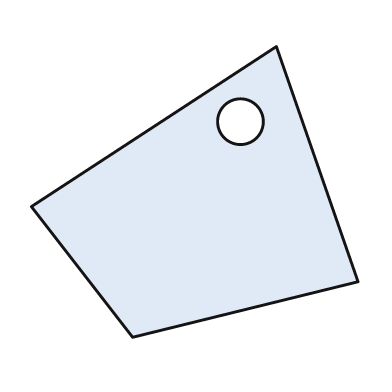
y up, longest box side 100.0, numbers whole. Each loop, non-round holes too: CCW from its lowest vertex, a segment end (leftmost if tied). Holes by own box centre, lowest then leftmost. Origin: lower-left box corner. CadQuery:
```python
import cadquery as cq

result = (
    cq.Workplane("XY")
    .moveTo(31.0, 0.0)
    .lineTo(100.0, 17.0)
    .lineTo(75.0, 89.0)
    .lineTo(0.0, 40.0)
    .close()
    .moveTo(64.0, 66.0)
    .circle(7.0)
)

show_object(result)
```